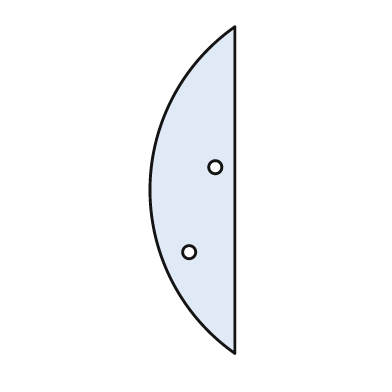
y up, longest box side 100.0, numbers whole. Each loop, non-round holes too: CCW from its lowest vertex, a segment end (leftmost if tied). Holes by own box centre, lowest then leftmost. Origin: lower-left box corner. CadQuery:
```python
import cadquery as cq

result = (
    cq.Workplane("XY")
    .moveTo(26.0, 0.0)
    .lineTo(26.0, 100.0)
    .threePointArc((0.0, 50.0), (26.0, 0.0))
    .close()
    .moveTo(12.0, 31.0)
    .circle(2.0)
    .moveTo(20.0, 57.0)
    .circle(2.0)
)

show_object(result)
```